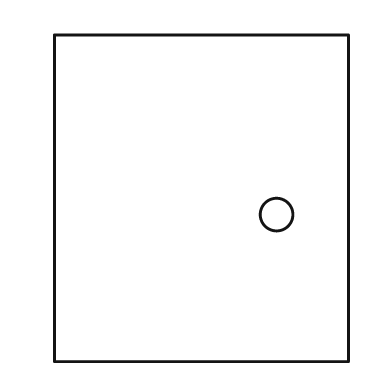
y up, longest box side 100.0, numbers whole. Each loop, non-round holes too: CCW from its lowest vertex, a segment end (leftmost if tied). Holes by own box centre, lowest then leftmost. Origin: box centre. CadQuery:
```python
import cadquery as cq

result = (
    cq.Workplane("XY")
    .moveTo(-45.0, -50.0)
    .lineTo(45.0, -50.0)
    .lineTo(45.0, 50.0)
    .lineTo(-45.0, 50.0)
    .close()
    .moveTo(23.0, -5.0)
    .circle(5.0)
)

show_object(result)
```